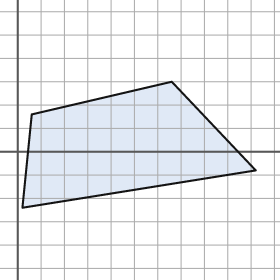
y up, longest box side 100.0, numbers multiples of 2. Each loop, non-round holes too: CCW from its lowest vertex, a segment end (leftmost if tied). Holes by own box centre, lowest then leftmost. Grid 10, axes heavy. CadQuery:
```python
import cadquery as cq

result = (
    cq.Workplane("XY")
    .moveTo(2.0, -24.0)
    .lineTo(102.0, -8.0)
    .lineTo(66.0, 30.0)
    .lineTo(6.0, 16.0)
    .close()
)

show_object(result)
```